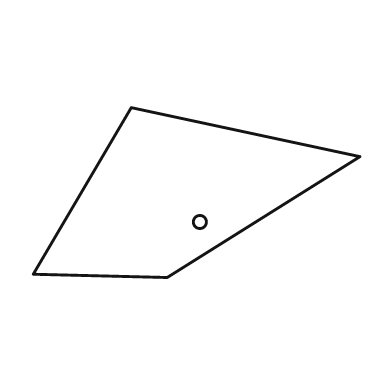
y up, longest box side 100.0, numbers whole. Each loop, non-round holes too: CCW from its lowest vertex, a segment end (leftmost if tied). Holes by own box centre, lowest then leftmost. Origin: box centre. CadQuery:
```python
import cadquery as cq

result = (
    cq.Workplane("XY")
    .moveTo(-9.0, -26.0)
    .lineTo(50.0, 11.0)
    .lineTo(-20.0, 26.0)
    .lineTo(-50.0, -25.0)
    .close()
    .moveTo(1.0, -9.0)
    .circle(2.0)
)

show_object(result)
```